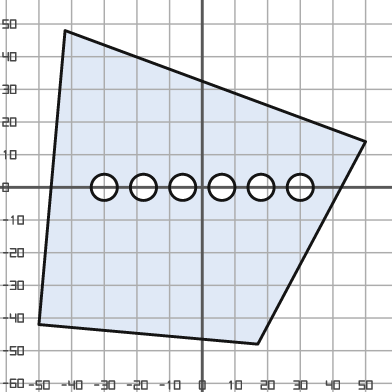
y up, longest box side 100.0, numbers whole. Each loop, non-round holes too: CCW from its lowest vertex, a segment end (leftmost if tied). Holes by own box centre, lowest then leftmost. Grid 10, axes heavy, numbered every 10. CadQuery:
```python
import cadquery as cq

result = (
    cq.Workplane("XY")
    .moveTo(17.0, -48.0)
    .lineTo(50.0, 14.0)
    .lineTo(-42.0, 48.0)
    .lineTo(-50.0, -42.0)
    .close()
    .moveTo(-30.0, 0.0)
    .circle(4.0)
    .moveTo(-18.0, 0.0)
    .circle(4.0)
    .moveTo(-6.0, 0.0)
    .circle(4.0)
    .moveTo(6.0, 0.0)
    .circle(4.0)
    .moveTo(18.0, 0.0)
    .circle(4.0)
    .moveTo(30.0, 0.0)
    .circle(4.0)
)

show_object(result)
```